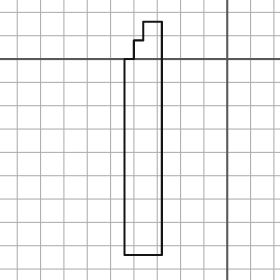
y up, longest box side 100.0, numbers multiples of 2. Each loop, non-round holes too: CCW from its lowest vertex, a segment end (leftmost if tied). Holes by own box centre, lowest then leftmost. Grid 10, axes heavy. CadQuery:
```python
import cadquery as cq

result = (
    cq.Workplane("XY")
    .moveTo(-44.0, -84.0)
    .lineTo(-28.0, -84.0)
    .lineTo(-28.0, 16.0)
    .lineTo(-36.0, 16.0)
    .lineTo(-36.0, 8.0)
    .lineTo(-40.0, 8.0)
    .lineTo(-40.0, 0.0)
    .lineTo(-44.0, 0.0)
    .close()
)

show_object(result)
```